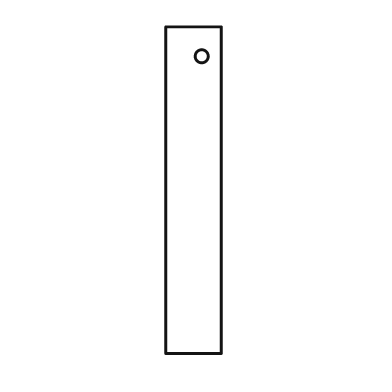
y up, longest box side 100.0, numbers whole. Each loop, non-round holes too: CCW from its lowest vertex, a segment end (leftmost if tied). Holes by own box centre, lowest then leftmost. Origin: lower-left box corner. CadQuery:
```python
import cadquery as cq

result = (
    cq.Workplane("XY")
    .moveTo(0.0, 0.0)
    .lineTo(17.0, 0.0)
    .lineTo(17.0, 100.0)
    .lineTo(0.0, 100.0)
    .close()
    .moveTo(11.0, 91.0)
    .circle(2.0)
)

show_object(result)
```